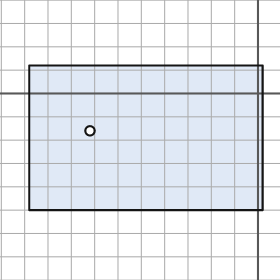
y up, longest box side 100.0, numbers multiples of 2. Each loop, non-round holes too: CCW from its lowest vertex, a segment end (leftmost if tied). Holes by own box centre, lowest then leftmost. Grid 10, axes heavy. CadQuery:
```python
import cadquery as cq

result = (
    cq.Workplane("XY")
    .moveTo(-98.0, -50.0)
    .lineTo(2.0, -50.0)
    .lineTo(2.0, 12.0)
    .lineTo(-98.0, 12.0)
    .close()
    .moveTo(-72.0, -16.0)
    .circle(2.0)
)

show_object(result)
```